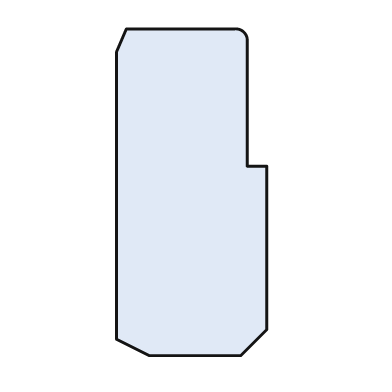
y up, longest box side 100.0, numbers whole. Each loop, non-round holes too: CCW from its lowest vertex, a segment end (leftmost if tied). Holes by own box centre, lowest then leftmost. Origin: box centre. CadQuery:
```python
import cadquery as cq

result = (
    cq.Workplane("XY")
    .moveTo(-13.0, -50.0)
    .lineTo(15.0, -50.0)
    .lineTo(23.0, -42.0)
    .lineTo(23.0, 8.0)
    .lineTo(17.0, 8.0)
    .lineTo(17.0, 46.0)
    .threePointArc((16.0, 49.0), (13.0, 50.0))
    .lineTo(-20.0, 50.0)
    .lineTo(-23.0, 43.0)
    .lineTo(-23.0, -45.0)
    .close()
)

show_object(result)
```